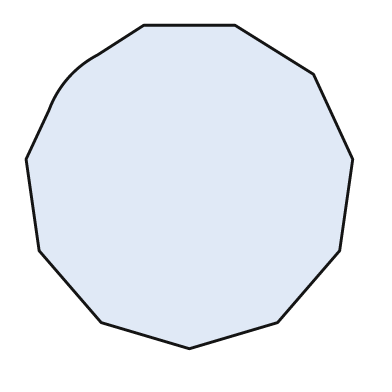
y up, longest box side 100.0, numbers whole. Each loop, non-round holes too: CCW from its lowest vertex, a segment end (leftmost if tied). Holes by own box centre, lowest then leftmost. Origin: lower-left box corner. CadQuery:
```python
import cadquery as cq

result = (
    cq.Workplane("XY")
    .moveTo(50.0, 0.0)
    .lineTo(77.0, 8.0)
    .lineTo(96.0, 30.0)
    .lineTo(100.0, 58.0)
    .lineTo(88.0, 84.0)
    .lineTo(64.0, 99.0)
    .lineTo(36.0, 99.0)
    .lineTo(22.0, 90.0)
    .threePointArc((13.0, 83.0), (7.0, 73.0))
    .lineTo(0.0, 58.0)
    .lineTo(4.0, 30.0)
    .lineTo(23.0, 8.0)
    .close()
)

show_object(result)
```